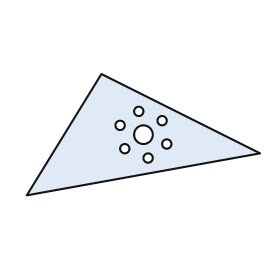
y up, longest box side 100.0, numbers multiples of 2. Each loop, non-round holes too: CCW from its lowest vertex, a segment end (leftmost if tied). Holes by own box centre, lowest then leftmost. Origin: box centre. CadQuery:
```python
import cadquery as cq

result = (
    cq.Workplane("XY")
    .moveTo(-50.0, -26.0)
    .lineTo(50.0, -8.0)
    .lineTo(-18.0, 26.0)
    .close()
    .moveTo(2.0, -10.0)
    .circle(2.0)
    .moveTo(-8.0, -6.0)
    .circle(2.0)
    .moveTo(10.0, -4.0)
    .circle(2.0)
    .moveTo(0.0, 0.0)
    .circle(4.0)
    .moveTo(-10.0, 4.0)
    .circle(2.0)
    .moveTo(8.0, 6.0)
    .circle(2.0)
    .moveTo(-2.0, 10.0)
    .circle(2.0)
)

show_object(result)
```